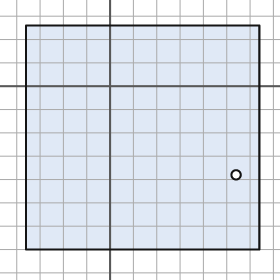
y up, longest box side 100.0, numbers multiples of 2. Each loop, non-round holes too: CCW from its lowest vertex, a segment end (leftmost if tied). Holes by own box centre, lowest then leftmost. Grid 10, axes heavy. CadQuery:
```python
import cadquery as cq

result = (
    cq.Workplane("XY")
    .moveTo(-36.0, -70.0)
    .lineTo(64.0, -70.0)
    .lineTo(64.0, 26.0)
    .lineTo(-36.0, 26.0)
    .close()
    .moveTo(54.0, -38.0)
    .circle(2.0)
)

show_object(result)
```